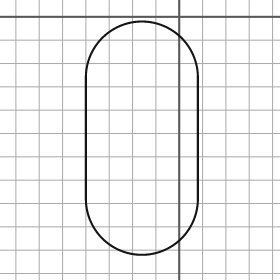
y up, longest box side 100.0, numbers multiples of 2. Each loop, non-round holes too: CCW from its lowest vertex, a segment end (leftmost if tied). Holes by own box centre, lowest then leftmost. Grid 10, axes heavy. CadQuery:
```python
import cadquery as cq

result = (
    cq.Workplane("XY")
    .moveTo(-40.0, -78.0)
    .threePointArc((-16.0, -102.0), (8.0, -78.0))
    .lineTo(8.0, -26.0)
    .threePointArc((-16.0, -2.0), (-40.0, -26.0))
    .close()
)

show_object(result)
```